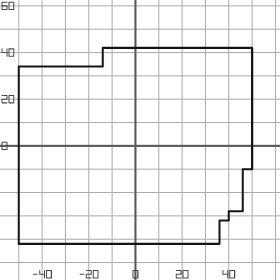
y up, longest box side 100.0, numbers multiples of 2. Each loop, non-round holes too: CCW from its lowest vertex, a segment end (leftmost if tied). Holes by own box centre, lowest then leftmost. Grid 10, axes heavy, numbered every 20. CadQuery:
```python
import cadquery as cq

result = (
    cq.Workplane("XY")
    .moveTo(-50.0, -42.0)
    .lineTo(36.0, -42.0)
    .lineTo(36.0, -32.0)
    .lineTo(40.0, -32.0)
    .lineTo(40.0, -28.0)
    .lineTo(46.0, -28.0)
    .lineTo(46.0, -10.0)
    .lineTo(50.0, -10.0)
    .lineTo(50.0, 42.0)
    .lineTo(-14.0, 42.0)
    .lineTo(-14.0, 34.0)
    .lineTo(-50.0, 34.0)
    .close()
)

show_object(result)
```